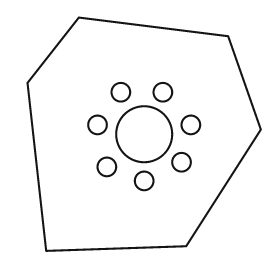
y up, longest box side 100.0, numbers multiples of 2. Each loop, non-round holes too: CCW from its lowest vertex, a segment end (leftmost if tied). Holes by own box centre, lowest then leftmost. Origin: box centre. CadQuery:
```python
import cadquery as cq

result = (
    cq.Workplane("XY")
    .moveTo(-42.0, -50.0)
    .lineTo(18.0, -48.0)
    .lineTo(50.0, 2.0)
    .lineTo(36.0, 42.0)
    .lineTo(-28.0, 50.0)
    .lineTo(-50.0, 22.0)
    .close()
    .moveTo(0.0, -20.0)
    .circle(4.0)
    .moveTo(-16.0, -14.0)
    .circle(4.0)
    .moveTo(16.0, -12.0)
    .circle(4.0)
    .moveTo(0.0, 0.0)
    .circle(12.0)
    .moveTo(-20.0, 4.0)
    .circle(4.0)
    .moveTo(20.0, 4.0)
    .circle(4.0)
    .moveTo(-10.0, 18.0)
    .circle(4.0)
    .moveTo(8.0, 18.0)
    .circle(4.0)
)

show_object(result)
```